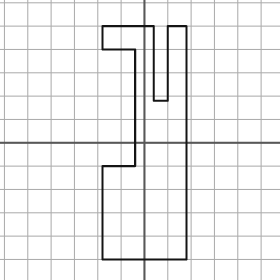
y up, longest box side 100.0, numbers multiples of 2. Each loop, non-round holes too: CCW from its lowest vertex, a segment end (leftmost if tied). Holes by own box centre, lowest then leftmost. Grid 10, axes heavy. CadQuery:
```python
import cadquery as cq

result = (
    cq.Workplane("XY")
    .moveTo(-18.0, -50.0)
    .lineTo(18.0, -50.0)
    .lineTo(18.0, 50.0)
    .lineTo(10.0, 50.0)
    .lineTo(10.0, 18.0)
    .lineTo(4.0, 18.0)
    .lineTo(4.0, 50.0)
    .lineTo(-18.0, 50.0)
    .lineTo(-18.0, 40.0)
    .lineTo(-4.0, 40.0)
    .lineTo(-4.0, -10.0)
    .lineTo(-18.0, -10.0)
    .close()
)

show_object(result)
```